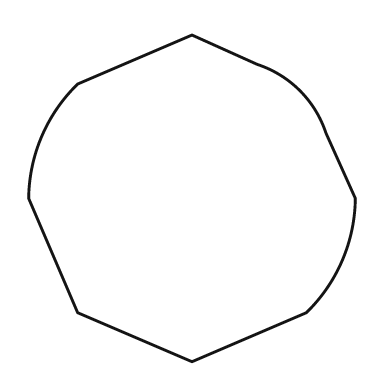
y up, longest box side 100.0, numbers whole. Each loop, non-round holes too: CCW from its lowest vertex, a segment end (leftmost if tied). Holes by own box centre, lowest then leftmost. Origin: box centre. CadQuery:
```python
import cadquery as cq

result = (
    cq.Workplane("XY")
    .moveTo(0.0, -50.0)
    .lineTo(35.0, -35.0)
    .threePointArc((46.0, -19.0), (50.0, 0.0))
    .lineTo(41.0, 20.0)
    .threePointArc((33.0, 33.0), (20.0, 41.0))
    .lineTo(0.0, 50.0)
    .lineTo(-35.0, 35.0)
    .threePointArc((-46.0, 19.0), (-50.0, 0.0))
    .lineTo(-35.0, -35.0)
    .close()
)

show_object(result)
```